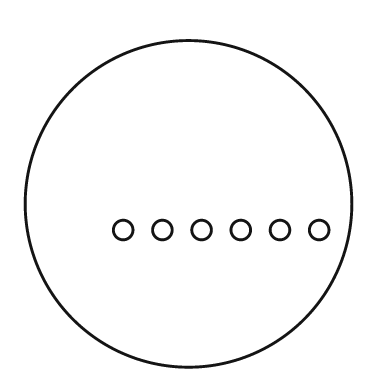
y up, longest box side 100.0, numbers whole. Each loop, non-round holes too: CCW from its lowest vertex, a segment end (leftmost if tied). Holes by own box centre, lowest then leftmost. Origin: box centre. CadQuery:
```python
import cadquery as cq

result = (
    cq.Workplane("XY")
    .moveTo(0.0, 0.0)
    .circle(50.0)
    .moveTo(-20.0, -8.0)
    .circle(3.0)
    .moveTo(-8.0, -8.0)
    .circle(3.0)
    .moveTo(4.0, -8.0)
    .circle(3.0)
    .moveTo(16.0, -8.0)
    .circle(3.0)
    .moveTo(28.0, -8.0)
    .circle(3.0)
    .moveTo(40.0, -8.0)
    .circle(3.0)
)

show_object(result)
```